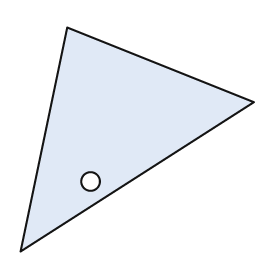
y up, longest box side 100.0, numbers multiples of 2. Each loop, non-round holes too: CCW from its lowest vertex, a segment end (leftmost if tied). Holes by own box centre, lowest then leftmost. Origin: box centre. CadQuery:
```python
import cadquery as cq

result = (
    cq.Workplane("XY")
    .moveTo(-50.0, -48.0)
    .lineTo(50.0, 16.0)
    .lineTo(-30.0, 48.0)
    .close()
    .moveTo(-20.0, -18.0)
    .circle(4.0)
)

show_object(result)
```